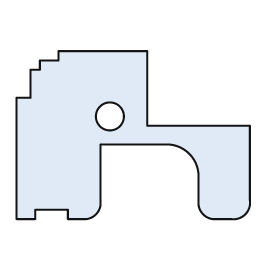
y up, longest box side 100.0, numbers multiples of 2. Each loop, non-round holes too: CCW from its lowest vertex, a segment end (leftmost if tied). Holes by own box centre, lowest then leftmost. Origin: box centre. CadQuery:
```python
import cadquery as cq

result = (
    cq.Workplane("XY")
    .moveTo(-50.0, -36.0)
    .lineTo(-42.0, -36.0)
    .lineTo(-42.0, -32.0)
    .lineTo(-28.0, -32.0)
    .lineTo(-28.0, -36.0)
    .lineTo(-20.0, -36.0)
    .threePointArc((-16.0, -34.0), (-14.0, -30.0))
    .lineTo(-14.0, -4.0)
    .lineTo(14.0, -4.0)
    .threePointArc((24.0, -8.0), (28.0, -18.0))
    .lineTo(28.0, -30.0)
    .threePointArc((30.0, -34.0), (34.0, -36.0))
    .lineTo(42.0, -36.0)
    .threePointArc((48.0, -34.0), (50.0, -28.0))
    .lineTo(50.0, 4.0)
    .lineTo(6.0, 4.0)
    .lineTo(6.0, 36.0)
    .lineTo(-32.0, 36.0)
    .lineTo(-32.0, 32.0)
    .lineTo(-40.0, 32.0)
    .lineTo(-40.0, 28.0)
    .lineTo(-44.0, 28.0)
    .lineTo(-44.0, 16.0)
    .lineTo(-50.0, 16.0)
    .close()
    .moveTo(-10.0, 8.0)
    .circle(6.0)
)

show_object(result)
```